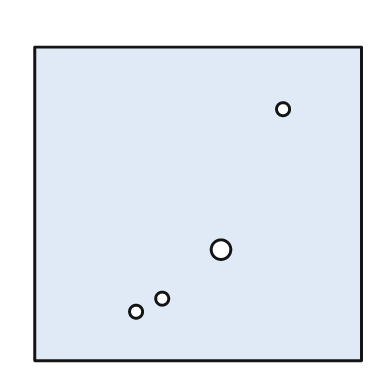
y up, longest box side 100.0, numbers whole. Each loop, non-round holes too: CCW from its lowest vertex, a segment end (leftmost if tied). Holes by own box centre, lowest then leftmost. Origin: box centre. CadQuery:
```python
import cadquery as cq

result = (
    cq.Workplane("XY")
    .moveTo(-50.0, -48.0)
    .lineTo(50.0, -48.0)
    .lineTo(50.0, 48.0)
    .lineTo(-50.0, 48.0)
    .close()
    .moveTo(-19.0, -33.0)
    .circle(2.0)
    .moveTo(-11.0, -29.0)
    .circle(2.0)
    .moveTo(7.0, -14.0)
    .circle(3.0)
    .moveTo(26.0, 29.0)
    .circle(2.0)
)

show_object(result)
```